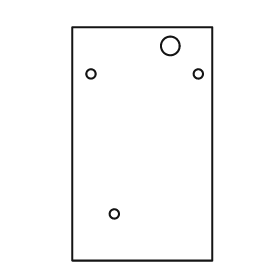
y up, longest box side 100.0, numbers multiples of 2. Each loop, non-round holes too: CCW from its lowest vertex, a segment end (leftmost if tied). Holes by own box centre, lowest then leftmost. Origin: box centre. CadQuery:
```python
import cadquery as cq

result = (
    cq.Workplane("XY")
    .moveTo(-30.0, -50.0)
    .lineTo(30.0, -50.0)
    .lineTo(30.0, 50.0)
    .lineTo(-30.0, 50.0)
    .close()
    .moveTo(-12.0, -30.0)
    .circle(2.0)
    .moveTo(-22.0, 30.0)
    .circle(2.0)
    .moveTo(24.0, 30.0)
    .circle(2.0)
    .moveTo(12.0, 42.0)
    .circle(4.0)
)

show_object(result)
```